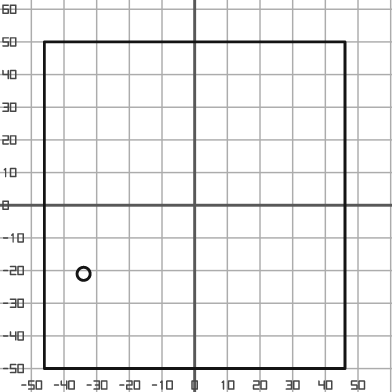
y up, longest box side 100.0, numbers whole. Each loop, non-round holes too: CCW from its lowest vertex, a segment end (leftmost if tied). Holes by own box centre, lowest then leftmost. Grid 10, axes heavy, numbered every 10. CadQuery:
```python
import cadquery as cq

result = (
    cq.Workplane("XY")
    .moveTo(-46.0, -50.0)
    .lineTo(46.0, -50.0)
    .lineTo(46.0, 50.0)
    .lineTo(-46.0, 50.0)
    .close()
    .moveTo(-34.0, -21.0)
    .circle(2.0)
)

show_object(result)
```